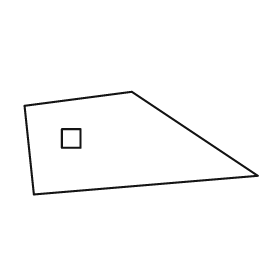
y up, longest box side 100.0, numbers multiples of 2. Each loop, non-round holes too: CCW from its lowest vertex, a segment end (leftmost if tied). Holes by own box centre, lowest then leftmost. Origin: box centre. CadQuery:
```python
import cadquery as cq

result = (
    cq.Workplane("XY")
    .moveTo(-46.0, -22.0)
    .lineTo(50.0, -14.0)
    .lineTo(-4.0, 22.0)
    .lineTo(-50.0, 16.0)
    .close()
    .moveTo(-34.0, -2.0)
    .lineTo(-26.0, -2.0)
    .lineTo(-26.0, 6.0)
    .lineTo(-34.0, 6.0)
    .close()
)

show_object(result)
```